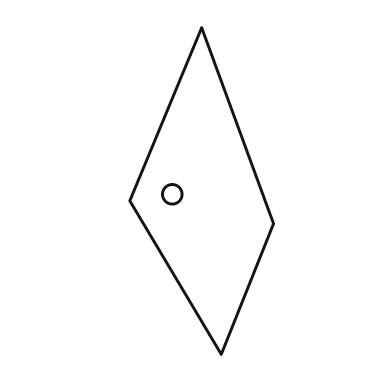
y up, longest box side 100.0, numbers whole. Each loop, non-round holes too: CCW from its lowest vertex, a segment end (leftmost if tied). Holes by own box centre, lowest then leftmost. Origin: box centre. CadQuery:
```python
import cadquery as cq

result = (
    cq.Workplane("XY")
    .moveTo(6.0, -50.0)
    .lineTo(22.0, -10.0)
    .lineTo(0.0, 50.0)
    .lineTo(-22.0, -3.0)
    .close()
    .moveTo(-9.0, -1.0)
    .circle(3.0)
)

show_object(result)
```